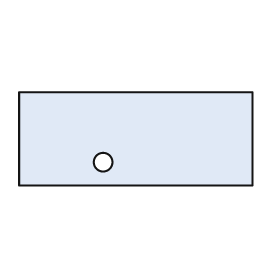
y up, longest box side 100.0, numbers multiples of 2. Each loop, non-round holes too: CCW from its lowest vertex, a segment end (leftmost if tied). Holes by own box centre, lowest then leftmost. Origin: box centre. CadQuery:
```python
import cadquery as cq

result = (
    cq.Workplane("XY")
    .moveTo(-50.0, -20.0)
    .lineTo(50.0, -20.0)
    .lineTo(50.0, 20.0)
    .lineTo(-50.0, 20.0)
    .close()
    .moveTo(-14.0, -10.0)
    .circle(4.0)
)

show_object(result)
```